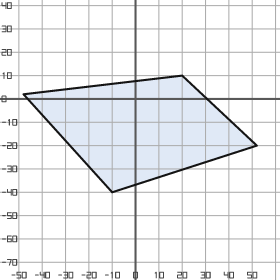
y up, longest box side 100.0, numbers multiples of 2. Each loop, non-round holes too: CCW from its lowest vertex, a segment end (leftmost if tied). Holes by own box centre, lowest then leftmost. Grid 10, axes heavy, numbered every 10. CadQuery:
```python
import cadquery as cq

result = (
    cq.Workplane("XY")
    .moveTo(-10.0, -40.0)
    .lineTo(52.0, -20.0)
    .lineTo(20.0, 10.0)
    .lineTo(-48.0, 2.0)
    .close()
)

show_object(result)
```